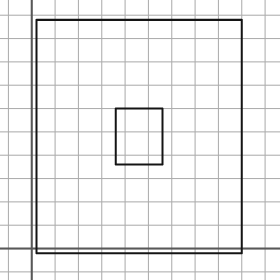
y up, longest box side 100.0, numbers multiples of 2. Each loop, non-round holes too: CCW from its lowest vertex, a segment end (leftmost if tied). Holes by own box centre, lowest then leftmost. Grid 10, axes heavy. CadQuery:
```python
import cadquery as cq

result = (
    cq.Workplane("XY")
    .moveTo(2.0, -2.0)
    .lineTo(90.0, -2.0)
    .lineTo(90.0, 98.0)
    .lineTo(2.0, 98.0)
    .close()
    .moveTo(36.0, 36.0)
    .lineTo(56.0, 36.0)
    .lineTo(56.0, 60.0)
    .lineTo(36.0, 60.0)
    .close()
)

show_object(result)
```